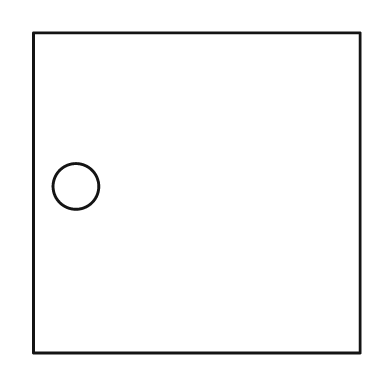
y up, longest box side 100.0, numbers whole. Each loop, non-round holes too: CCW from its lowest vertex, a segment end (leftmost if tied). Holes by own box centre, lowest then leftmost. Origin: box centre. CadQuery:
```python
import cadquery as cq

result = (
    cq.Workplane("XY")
    .moveTo(-50.0, -49.0)
    .lineTo(50.0, -49.0)
    .lineTo(50.0, 49.0)
    .lineTo(-50.0, 49.0)
    .close()
    .moveTo(-37.0, 2.0)
    .circle(7.0)
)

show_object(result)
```